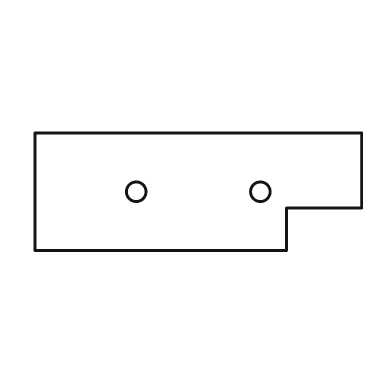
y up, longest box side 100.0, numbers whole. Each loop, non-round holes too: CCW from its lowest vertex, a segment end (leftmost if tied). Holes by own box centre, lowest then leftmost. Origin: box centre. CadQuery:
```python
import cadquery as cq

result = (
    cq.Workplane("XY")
    .moveTo(-50.0, -18.0)
    .lineTo(27.0, -18.0)
    .lineTo(27.0, -5.0)
    .lineTo(50.0, -5.0)
    .lineTo(50.0, 18.0)
    .lineTo(-50.0, 18.0)
    .close()
    .moveTo(-19.0, 0.0)
    .circle(3.0)
    .moveTo(19.0, 0.0)
    .circle(3.0)
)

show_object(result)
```